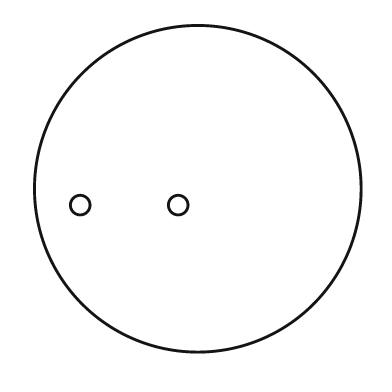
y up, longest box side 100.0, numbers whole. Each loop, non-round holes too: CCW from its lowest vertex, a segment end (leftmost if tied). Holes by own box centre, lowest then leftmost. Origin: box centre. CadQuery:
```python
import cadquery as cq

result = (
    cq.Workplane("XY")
    .moveTo(0.0, 0.0)
    .circle(50.0)
    .moveTo(-36.0, -5.0)
    .circle(3.0)
    .moveTo(-6.0, -5.0)
    .circle(3.0)
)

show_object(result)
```